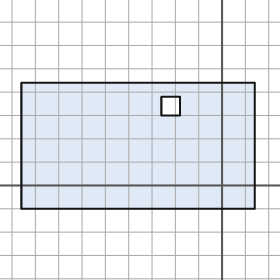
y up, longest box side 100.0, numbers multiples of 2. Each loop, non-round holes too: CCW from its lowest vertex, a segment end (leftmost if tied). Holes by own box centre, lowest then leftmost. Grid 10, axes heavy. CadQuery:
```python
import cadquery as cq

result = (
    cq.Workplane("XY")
    .moveTo(-86.0, -10.0)
    .lineTo(14.0, -10.0)
    .lineTo(14.0, 44.0)
    .lineTo(-86.0, 44.0)
    .close()
    .moveTo(-26.0, 30.0)
    .lineTo(-18.0, 30.0)
    .lineTo(-18.0, 38.0)
    .lineTo(-26.0, 38.0)
    .close()
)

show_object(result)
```